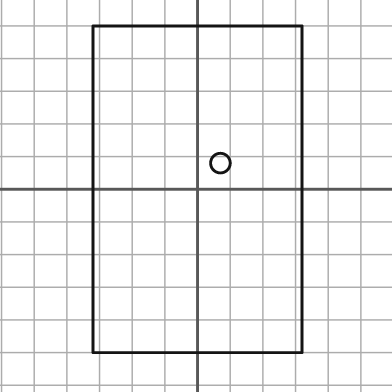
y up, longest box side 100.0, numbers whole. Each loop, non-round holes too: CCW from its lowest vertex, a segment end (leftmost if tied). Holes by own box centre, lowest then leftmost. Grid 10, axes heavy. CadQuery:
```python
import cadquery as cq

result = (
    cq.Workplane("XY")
    .moveTo(-32.0, -50.0)
    .lineTo(32.0, -50.0)
    .lineTo(32.0, 50.0)
    .lineTo(-32.0, 50.0)
    .close()
    .moveTo(7.0, 8.0)
    .circle(3.0)
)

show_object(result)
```